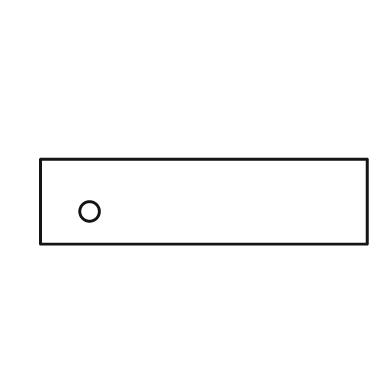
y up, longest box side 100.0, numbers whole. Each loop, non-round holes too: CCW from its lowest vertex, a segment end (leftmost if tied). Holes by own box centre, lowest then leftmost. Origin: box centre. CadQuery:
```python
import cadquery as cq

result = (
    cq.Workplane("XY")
    .moveTo(-50.0, -13.0)
    .lineTo(50.0, -13.0)
    .lineTo(50.0, 13.0)
    .lineTo(-50.0, 13.0)
    .close()
    .moveTo(-35.0, -3.0)
    .circle(3.0)
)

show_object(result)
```